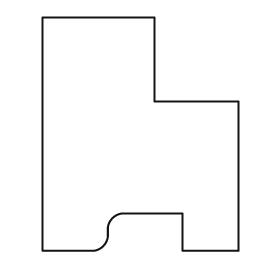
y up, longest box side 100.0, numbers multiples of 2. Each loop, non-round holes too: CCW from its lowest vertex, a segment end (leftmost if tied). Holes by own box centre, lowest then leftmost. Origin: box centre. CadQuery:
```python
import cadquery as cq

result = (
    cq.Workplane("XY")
    .moveTo(-42.0, -50.0)
    .lineTo(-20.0, -50.0)
    .threePointArc((-16.0, -48.0), (-14.0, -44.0))
    .lineTo(-14.0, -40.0)
    .threePointArc((-12.0, -36.0), (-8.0, -34.0))
    .lineTo(18.0, -34.0)
    .lineTo(18.0, -50.0)
    .lineTo(42.0, -50.0)
    .lineTo(42.0, 14.0)
    .lineTo(6.0, 14.0)
    .lineTo(6.0, 50.0)
    .lineTo(-42.0, 50.0)
    .close()
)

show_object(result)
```